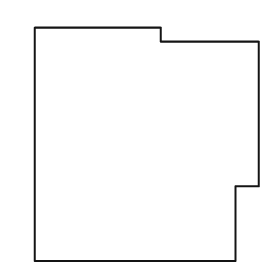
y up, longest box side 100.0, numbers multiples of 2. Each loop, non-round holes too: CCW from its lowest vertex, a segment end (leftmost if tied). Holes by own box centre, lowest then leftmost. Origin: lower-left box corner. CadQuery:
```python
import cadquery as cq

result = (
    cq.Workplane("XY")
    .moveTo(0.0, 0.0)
    .lineTo(86.0, 0.0)
    .lineTo(86.0, 32.0)
    .lineTo(96.0, 32.0)
    .lineTo(96.0, 94.0)
    .lineTo(54.0, 94.0)
    .lineTo(54.0, 100.0)
    .lineTo(0.0, 100.0)
    .close()
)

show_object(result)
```